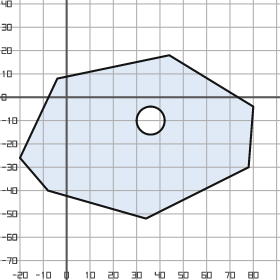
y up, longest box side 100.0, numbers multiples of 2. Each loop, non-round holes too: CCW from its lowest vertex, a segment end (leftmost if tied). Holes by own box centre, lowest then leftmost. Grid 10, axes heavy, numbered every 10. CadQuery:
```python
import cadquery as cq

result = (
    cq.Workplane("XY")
    .moveTo(34.0, -52.0)
    .lineTo(78.0, -30.0)
    .lineTo(80.0, -4.0)
    .lineTo(44.0, 18.0)
    .lineTo(-4.0, 8.0)
    .lineTo(-20.0, -26.0)
    .lineTo(-8.0, -40.0)
    .close()
    .moveTo(36.0, -10.0)
    .circle(6.0)
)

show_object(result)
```